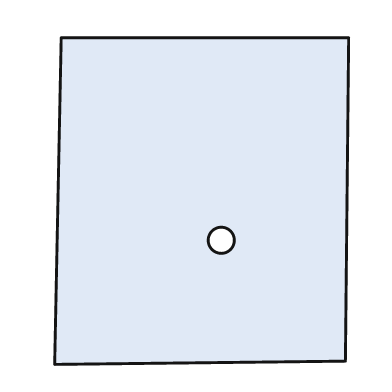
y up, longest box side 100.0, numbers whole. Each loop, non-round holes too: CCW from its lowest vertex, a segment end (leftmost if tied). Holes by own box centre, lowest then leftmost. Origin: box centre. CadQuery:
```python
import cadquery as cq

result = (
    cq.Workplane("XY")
    .moveTo(-45.0, -50.0)
    .lineTo(44.0, -49.0)
    .lineTo(45.0, 50.0)
    .lineTo(-43.0, 50.0)
    .close()
    .moveTo(6.0, -12.0)
    .circle(4.0)
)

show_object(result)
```